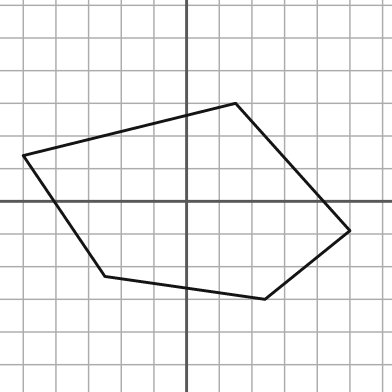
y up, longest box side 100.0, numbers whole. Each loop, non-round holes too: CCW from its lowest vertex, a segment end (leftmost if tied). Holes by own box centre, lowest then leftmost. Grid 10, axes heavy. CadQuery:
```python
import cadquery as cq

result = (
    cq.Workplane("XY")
    .moveTo(24.0, -30.0)
    .lineTo(50.0, -9.0)
    .lineTo(15.0, 30.0)
    .lineTo(-50.0, 14.0)
    .lineTo(-25.0, -23.0)
    .close()
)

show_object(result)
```